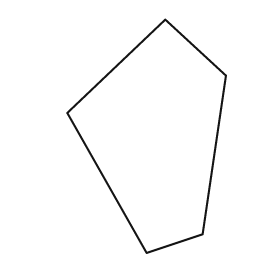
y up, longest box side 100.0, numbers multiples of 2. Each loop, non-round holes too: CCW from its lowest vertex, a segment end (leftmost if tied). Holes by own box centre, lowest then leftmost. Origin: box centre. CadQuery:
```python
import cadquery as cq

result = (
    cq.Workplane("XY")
    .moveTo(0.0, -50.0)
    .lineTo(24.0, -42.0)
    .lineTo(34.0, 26.0)
    .lineTo(8.0, 50.0)
    .lineTo(-34.0, 10.0)
    .close()
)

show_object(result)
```